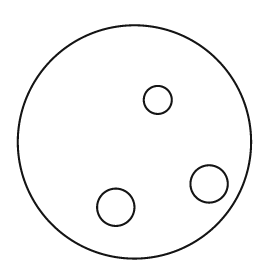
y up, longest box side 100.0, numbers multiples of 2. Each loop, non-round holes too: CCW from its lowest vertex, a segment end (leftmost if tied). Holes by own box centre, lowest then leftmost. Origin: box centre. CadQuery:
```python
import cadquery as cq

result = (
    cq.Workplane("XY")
    .moveTo(0.0, 0.0)
    .circle(50.0)
    .moveTo(-8.0, -28.0)
    .circle(8.0)
    .moveTo(32.0, -18.0)
    .circle(8.0)
    .moveTo(10.0, 18.0)
    .circle(6.0)
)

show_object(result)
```